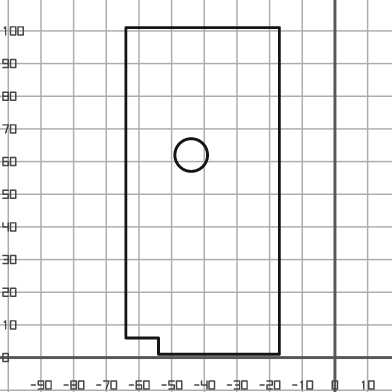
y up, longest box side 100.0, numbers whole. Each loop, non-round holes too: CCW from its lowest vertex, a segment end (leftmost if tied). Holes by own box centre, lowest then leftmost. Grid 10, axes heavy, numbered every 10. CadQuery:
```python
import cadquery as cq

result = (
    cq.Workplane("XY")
    .moveTo(-54.0, 1.0)
    .lineTo(-17.0, 1.0)
    .lineTo(-17.0, 101.0)
    .lineTo(-64.0, 101.0)
    .lineTo(-64.0, 6.0)
    .lineTo(-54.0, 6.0)
    .close()
    .moveTo(-44.0, 62.0)
    .circle(5.0)
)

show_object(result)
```